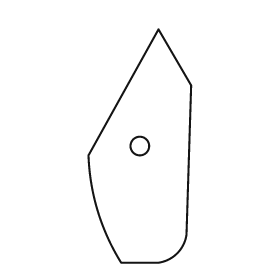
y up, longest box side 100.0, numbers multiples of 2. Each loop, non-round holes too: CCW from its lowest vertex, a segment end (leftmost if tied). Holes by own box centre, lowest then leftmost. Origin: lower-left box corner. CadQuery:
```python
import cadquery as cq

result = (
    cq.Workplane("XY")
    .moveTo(14.0, 0.0)
    .lineTo(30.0, 0.0)
    .threePointArc((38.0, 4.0), (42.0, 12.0))
    .lineTo(44.0, 76.0)
    .lineTo(30.0, 100.0)
    .lineTo(0.0, 46.0)
    .threePointArc((4.0, 22.0), (14.0, 0.0))
    .close()
    .moveTo(22.0, 50.0)
    .circle(4.0)
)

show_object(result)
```